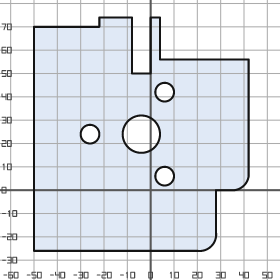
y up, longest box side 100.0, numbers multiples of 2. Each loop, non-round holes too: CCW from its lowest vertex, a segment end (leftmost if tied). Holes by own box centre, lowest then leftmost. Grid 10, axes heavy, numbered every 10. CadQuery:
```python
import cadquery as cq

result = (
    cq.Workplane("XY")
    .moveTo(-50.0, -26.0)
    .lineTo(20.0, -26.0)
    .threePointArc((26.0, -24.0), (28.0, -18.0))
    .lineTo(28.0, 0.0)
    .lineTo(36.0, 0.0)
    .threePointArc((40.0, 2.0), (42.0, 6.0))
    .lineTo(42.0, 56.0)
    .lineTo(4.0, 56.0)
    .lineTo(4.0, 74.0)
    .lineTo(0.0, 74.0)
    .lineTo(0.0, 50.0)
    .lineTo(-8.0, 50.0)
    .lineTo(-8.0, 74.0)
    .lineTo(-22.0, 74.0)
    .lineTo(-22.0, 70.0)
    .lineTo(-50.0, 70.0)
    .close()
    .moveTo(6.0, 6.0)
    .circle(4.0)
    .moveTo(-26.0, 24.0)
    .circle(4.0)
    .moveTo(-4.0, 24.0)
    .circle(8.0)
    .moveTo(6.0, 42.0)
    .circle(4.0)
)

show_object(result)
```